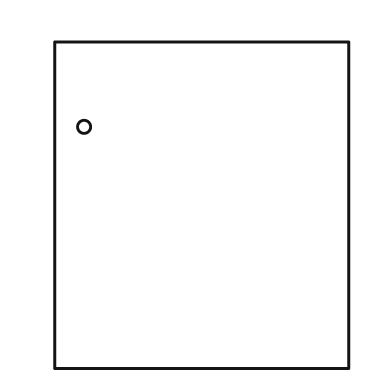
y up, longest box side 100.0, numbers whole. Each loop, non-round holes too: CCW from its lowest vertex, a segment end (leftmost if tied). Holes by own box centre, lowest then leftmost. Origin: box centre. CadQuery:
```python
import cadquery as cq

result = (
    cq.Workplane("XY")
    .moveTo(-45.0, -50.0)
    .lineTo(45.0, -50.0)
    .lineTo(45.0, 50.0)
    .lineTo(-45.0, 50.0)
    .close()
    .moveTo(-36.0, 24.0)
    .circle(2.0)
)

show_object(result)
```